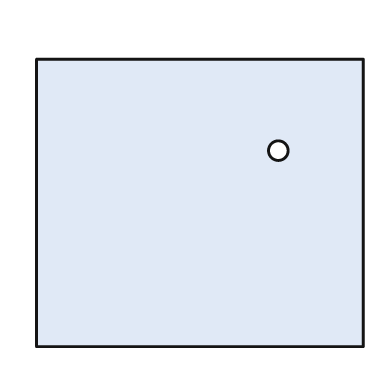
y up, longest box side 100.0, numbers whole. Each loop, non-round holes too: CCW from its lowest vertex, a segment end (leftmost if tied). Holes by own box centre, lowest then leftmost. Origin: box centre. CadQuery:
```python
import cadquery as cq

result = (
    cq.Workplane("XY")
    .moveTo(-50.0, -44.0)
    .lineTo(50.0, -44.0)
    .lineTo(50.0, 44.0)
    .lineTo(-50.0, 44.0)
    .close()
    .moveTo(24.0, 16.0)
    .circle(3.0)
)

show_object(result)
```